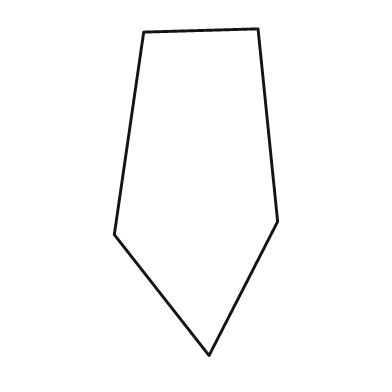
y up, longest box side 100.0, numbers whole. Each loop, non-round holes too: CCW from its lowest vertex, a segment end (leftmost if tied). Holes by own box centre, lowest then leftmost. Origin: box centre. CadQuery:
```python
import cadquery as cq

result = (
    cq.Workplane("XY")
    .moveTo(4.0, -50.0)
    .lineTo(25.0, -9.0)
    .lineTo(19.0, 50.0)
    .lineTo(-16.0, 49.0)
    .lineTo(-25.0, -13.0)
    .close()
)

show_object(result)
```